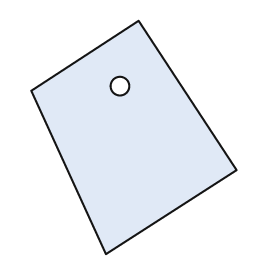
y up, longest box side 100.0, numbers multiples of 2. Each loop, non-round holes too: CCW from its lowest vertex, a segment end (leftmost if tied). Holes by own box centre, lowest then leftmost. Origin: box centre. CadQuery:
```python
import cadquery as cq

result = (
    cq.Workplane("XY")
    .moveTo(-12.0, -50.0)
    .lineTo(44.0, -14.0)
    .lineTo(2.0, 50.0)
    .lineTo(-44.0, 20.0)
    .close()
    .moveTo(-6.0, 22.0)
    .circle(4.0)
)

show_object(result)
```